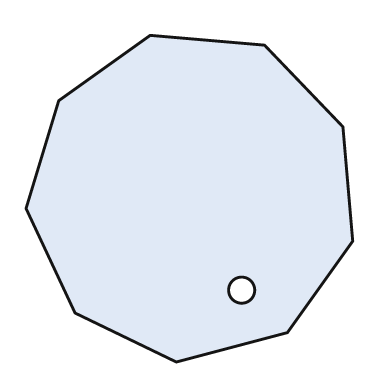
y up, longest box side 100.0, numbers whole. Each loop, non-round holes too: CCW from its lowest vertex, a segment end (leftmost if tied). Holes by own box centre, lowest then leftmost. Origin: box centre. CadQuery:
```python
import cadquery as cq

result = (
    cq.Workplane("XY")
    .moveTo(-4.0, -50.0)
    .lineTo(30.0, -41.0)
    .lineTo(50.0, -13.0)
    .lineTo(47.0, 22.0)
    .lineTo(23.0, 47.0)
    .lineTo(-12.0, 50.0)
    .lineTo(-40.0, 30.0)
    .lineTo(-50.0, -3.0)
    .lineTo(-35.0, -35.0)
    .close()
    .moveTo(16.0, -28.0)
    .circle(4.0)
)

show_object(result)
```